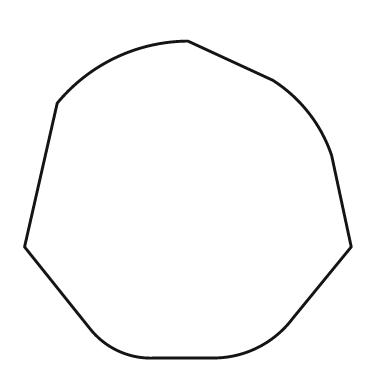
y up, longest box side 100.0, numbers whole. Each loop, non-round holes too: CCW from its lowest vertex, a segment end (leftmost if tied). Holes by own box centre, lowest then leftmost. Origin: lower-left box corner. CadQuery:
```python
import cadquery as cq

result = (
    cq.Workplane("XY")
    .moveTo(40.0, 0.0)
    .lineTo(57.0, 0.0)
    .threePointArc((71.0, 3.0), (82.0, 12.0))
    .lineTo(100.0, 34.0)
    .lineTo(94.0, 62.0)
    .threePointArc((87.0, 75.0), (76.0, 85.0))
    .lineTo(50.0, 97.0)
    .threePointArc((28.0, 92.0), (10.0, 78.0))
    .lineTo(0.0, 34.0)
    .lineTo(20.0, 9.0)
    .threePointArc((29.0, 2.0), (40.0, 0.0))
    .close()
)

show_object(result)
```